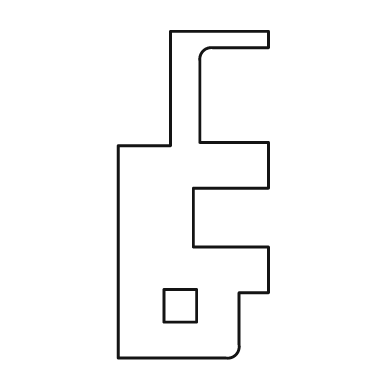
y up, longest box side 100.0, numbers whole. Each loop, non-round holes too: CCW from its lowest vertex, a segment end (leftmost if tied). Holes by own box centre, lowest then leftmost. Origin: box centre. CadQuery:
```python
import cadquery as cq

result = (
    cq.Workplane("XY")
    .moveTo(-23.0, -50.0)
    .lineTo(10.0, -50.0)
    .threePointArc((13.0, -49.0), (14.0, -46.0))
    .lineTo(14.0, -30.0)
    .lineTo(23.0, -30.0)
    .lineTo(23.0, -16.0)
    .lineTo(0.0, -16.0)
    .lineTo(0.0, 2.0)
    .lineTo(23.0, 2.0)
    .lineTo(23.0, 16.0)
    .lineTo(2.0, 16.0)
    .lineTo(2.0, 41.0)
    .threePointArc((3.0, 44.0), (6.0, 45.0))
    .lineTo(23.0, 45.0)
    .lineTo(23.0, 50.0)
    .lineTo(-7.0, 50.0)
    .lineTo(-7.0, 15.0)
    .lineTo(-23.0, 15.0)
    .close()
    .moveTo(-9.0, -39.0)
    .lineTo(1.0, -39.0)
    .lineTo(1.0, -29.0)
    .lineTo(-9.0, -29.0)
    .close()
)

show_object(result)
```